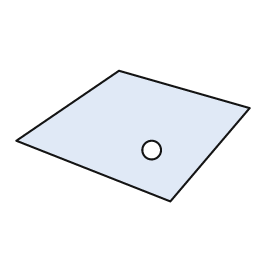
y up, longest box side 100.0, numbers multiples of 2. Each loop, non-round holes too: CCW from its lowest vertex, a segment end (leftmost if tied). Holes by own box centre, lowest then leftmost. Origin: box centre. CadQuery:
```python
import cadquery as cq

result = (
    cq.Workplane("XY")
    .moveTo(16.0, -28.0)
    .lineTo(50.0, 12.0)
    .lineTo(-6.0, 28.0)
    .lineTo(-50.0, -2.0)
    .close()
    .moveTo(8.0, -6.0)
    .circle(4.0)
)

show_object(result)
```